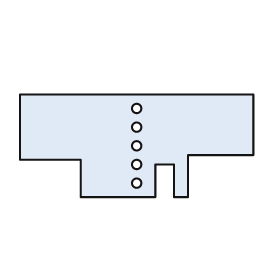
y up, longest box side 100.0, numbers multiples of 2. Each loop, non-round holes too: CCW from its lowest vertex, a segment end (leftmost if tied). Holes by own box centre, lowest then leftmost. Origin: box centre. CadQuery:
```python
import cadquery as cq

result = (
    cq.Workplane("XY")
    .moveTo(-24.0, -22.0)
    .lineTo(8.0, -22.0)
    .lineTo(8.0, -8.0)
    .lineTo(16.0, -8.0)
    .lineTo(16.0, -22.0)
    .lineTo(22.0, -22.0)
    .lineTo(22.0, -4.0)
    .lineTo(50.0, -4.0)
    .lineTo(50.0, 22.0)
    .lineTo(-50.0, 22.0)
    .lineTo(-50.0, -6.0)
    .lineTo(-24.0, -6.0)
    .close()
    .moveTo(0.0, -16.0)
    .circle(2.0)
    .moveTo(0.0, -8.0)
    .circle(2.0)
    .moveTo(0.0, 0.0)
    .circle(2.0)
    .moveTo(0.0, 8.0)
    .circle(2.0)
    .moveTo(0.0, 16.0)
    .circle(2.0)
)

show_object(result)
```